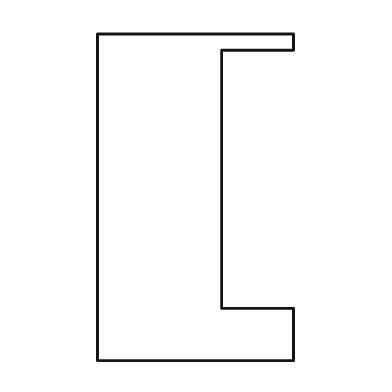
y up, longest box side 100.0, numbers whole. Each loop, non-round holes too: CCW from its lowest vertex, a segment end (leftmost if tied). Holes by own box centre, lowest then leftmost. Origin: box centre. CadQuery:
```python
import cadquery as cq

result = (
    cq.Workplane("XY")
    .moveTo(-30.0, -50.0)
    .lineTo(30.0, -50.0)
    .lineTo(30.0, -34.0)
    .lineTo(8.0, -34.0)
    .lineTo(8.0, 45.0)
    .lineTo(30.0, 45.0)
    .lineTo(30.0, 50.0)
    .lineTo(-30.0, 50.0)
    .close()
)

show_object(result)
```